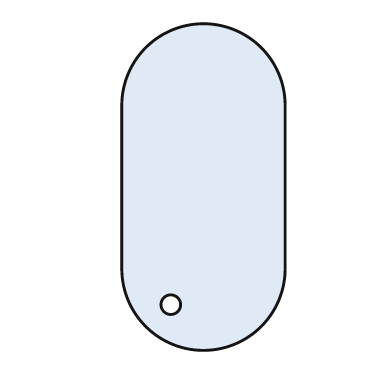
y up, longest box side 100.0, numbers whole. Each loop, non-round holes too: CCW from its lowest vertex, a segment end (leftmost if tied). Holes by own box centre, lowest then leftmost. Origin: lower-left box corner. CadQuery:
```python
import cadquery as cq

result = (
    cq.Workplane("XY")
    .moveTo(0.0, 25.0)
    .threePointArc((25.0, 0.0), (50.0, 25.0))
    .lineTo(50.0, 75.0)
    .threePointArc((25.0, 100.0), (0.0, 75.0))
    .close()
    .moveTo(15.0, 14.0)
    .circle(3.0)
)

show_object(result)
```